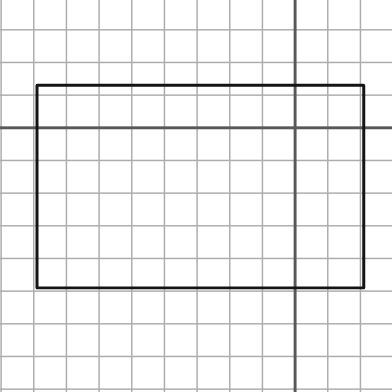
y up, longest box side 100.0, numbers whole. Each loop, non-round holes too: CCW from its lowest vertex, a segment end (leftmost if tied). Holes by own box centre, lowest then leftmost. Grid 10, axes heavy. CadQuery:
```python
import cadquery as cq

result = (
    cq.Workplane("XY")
    .moveTo(-79.0, -49.0)
    .lineTo(21.0, -49.0)
    .lineTo(21.0, 13.0)
    .lineTo(-79.0, 13.0)
    .close()
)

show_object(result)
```